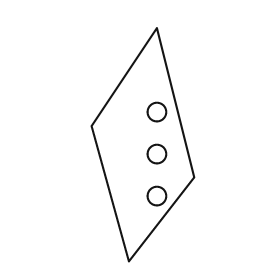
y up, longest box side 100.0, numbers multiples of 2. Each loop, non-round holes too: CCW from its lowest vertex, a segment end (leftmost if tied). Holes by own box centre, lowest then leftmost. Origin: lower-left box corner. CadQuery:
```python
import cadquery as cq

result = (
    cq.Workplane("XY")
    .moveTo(16.0, 0.0)
    .lineTo(44.0, 36.0)
    .lineTo(28.0, 100.0)
    .lineTo(0.0, 58.0)
    .close()
    .moveTo(28.0, 28.0)
    .circle(4.0)
    .moveTo(28.0, 46.0)
    .circle(4.0)
    .moveTo(28.0, 64.0)
    .circle(4.0)
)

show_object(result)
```